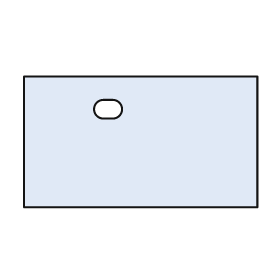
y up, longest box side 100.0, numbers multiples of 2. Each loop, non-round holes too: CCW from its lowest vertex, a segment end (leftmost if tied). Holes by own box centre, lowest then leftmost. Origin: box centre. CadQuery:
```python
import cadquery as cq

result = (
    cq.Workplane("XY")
    .moveTo(-50.0, -28.0)
    .lineTo(50.0, -28.0)
    .lineTo(50.0, 28.0)
    .lineTo(-50.0, 28.0)
    .close()
    .moveTo(-16.0, 10.0)
    .lineTo(-12.0, 10.0)
    .threePointArc((-8.0, 14.0), (-12.0, 18.0))
    .lineTo(-16.0, 18.0)
    .threePointArc((-20.0, 14.0), (-16.0, 10.0))
    .close()
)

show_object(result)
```